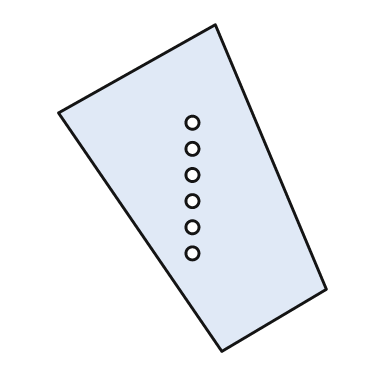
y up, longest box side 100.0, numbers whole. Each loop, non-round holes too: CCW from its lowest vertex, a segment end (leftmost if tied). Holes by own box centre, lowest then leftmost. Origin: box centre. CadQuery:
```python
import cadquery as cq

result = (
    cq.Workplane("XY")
    .moveTo(9.0, -50.0)
    .lineTo(41.0, -31.0)
    .lineTo(7.0, 50.0)
    .lineTo(-41.0, 23.0)
    .close()
    .moveTo(0.0, -20.0)
    .circle(2.0)
    .moveTo(0.0, -12.0)
    .circle(2.0)
    .moveTo(0.0, -4.0)
    .circle(2.0)
    .moveTo(0.0, 4.0)
    .circle(2.0)
    .moveTo(0.0, 12.0)
    .circle(2.0)
    .moveTo(0.0, 20.0)
    .circle(2.0)
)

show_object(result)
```